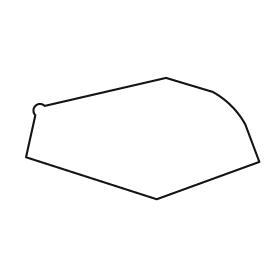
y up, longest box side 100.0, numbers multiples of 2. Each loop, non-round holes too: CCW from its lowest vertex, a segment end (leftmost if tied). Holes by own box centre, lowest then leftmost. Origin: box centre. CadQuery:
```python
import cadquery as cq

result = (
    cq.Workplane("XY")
    .moveTo(6.0, -26.0)
    .lineTo(50.0, -10.0)
    .lineTo(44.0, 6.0)
    .threePointArc((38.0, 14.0), (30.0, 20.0))
    .lineTo(10.0, 26.0)
    .lineTo(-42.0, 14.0)
    .threePointArc((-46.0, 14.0), (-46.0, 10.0))
    .lineTo(-50.0, -8.0)
    .close()
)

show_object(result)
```